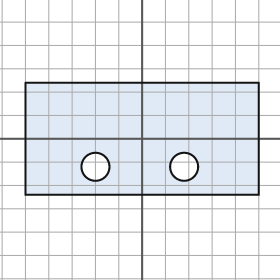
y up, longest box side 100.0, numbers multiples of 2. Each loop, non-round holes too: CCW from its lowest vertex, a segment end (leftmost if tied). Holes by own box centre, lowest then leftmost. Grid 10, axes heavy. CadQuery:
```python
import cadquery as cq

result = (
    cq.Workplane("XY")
    .moveTo(-50.0, -24.0)
    .lineTo(50.0, -24.0)
    .lineTo(50.0, 24.0)
    .lineTo(-50.0, 24.0)
    .close()
    .moveTo(-20.0, -12.0)
    .circle(6.0)
    .moveTo(18.0, -12.0)
    .circle(6.0)
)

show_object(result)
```